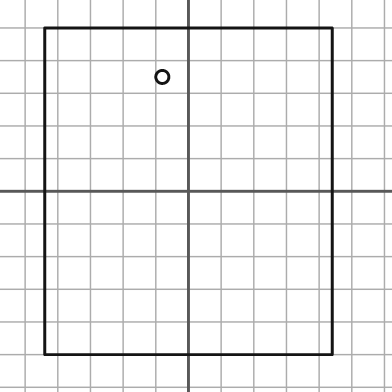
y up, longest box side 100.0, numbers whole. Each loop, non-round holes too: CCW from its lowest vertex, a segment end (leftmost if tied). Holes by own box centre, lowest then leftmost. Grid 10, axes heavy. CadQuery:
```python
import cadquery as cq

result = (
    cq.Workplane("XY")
    .moveTo(-44.0, -50.0)
    .lineTo(44.0, -50.0)
    .lineTo(44.0, 50.0)
    .lineTo(-44.0, 50.0)
    .close()
    .moveTo(-8.0, 35.0)
    .circle(2.0)
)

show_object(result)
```